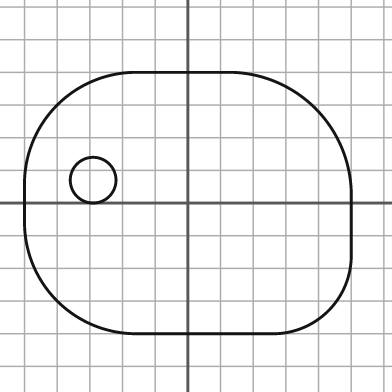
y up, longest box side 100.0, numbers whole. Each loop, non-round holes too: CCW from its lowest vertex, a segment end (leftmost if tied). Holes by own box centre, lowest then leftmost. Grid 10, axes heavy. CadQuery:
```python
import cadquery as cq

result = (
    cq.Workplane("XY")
    .moveTo(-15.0, -40.0)
    .lineTo(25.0, -40.0)
    .threePointArc((43.0, -33.0), (50.0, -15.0))
    .lineTo(50.0, 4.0)
    .threePointArc((39.0, 29.0), (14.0, 40.0))
    .lineTo(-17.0, 40.0)
    .threePointArc((-40.0, 30.0), (-50.0, 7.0))
    .lineTo(-50.0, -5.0)
    .threePointArc((-40.0, -30.0), (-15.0, -40.0))
    .close()
    .moveTo(-29.0, 7.0)
    .circle(7.0)
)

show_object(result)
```